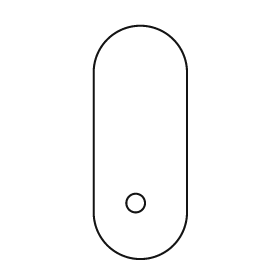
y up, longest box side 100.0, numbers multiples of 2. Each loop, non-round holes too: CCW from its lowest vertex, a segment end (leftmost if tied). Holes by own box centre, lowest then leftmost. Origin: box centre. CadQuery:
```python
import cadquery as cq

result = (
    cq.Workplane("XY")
    .moveTo(-20.0, -30.0)
    .threePointArc((0.0, -50.0), (20.0, -30.0))
    .lineTo(20.0, 30.0)
    .threePointArc((0.0, 50.0), (-20.0, 30.0))
    .close()
    .moveTo(-2.0, -26.0)
    .circle(4.0)
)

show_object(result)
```